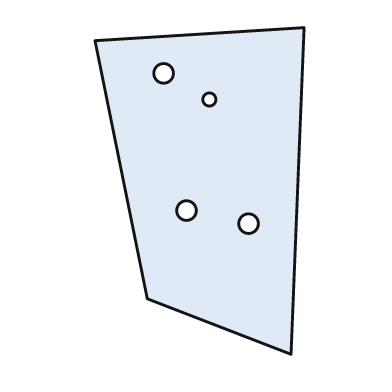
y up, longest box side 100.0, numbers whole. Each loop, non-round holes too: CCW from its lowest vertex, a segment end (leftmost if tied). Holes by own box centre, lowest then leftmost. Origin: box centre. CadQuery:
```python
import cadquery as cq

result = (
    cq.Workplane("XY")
    .moveTo(28.0, -50.0)
    .lineTo(32.0, 50.0)
    .lineTo(-32.0, 46.0)
    .lineTo(-16.0, -33.0)
    .close()
    .moveTo(15.0, -10.0)
    .circle(3.0)
    .moveTo(-4.0, -6.0)
    .circle(3.0)
    .moveTo(3.0, 28.0)
    .circle(2.0)
    .moveTo(-11.0, 36.0)
    .circle(3.0)
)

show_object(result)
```